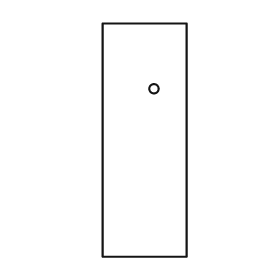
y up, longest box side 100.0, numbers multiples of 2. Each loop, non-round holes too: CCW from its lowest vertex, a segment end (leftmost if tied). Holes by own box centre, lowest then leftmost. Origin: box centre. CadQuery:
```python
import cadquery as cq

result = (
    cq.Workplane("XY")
    .moveTo(-18.0, -50.0)
    .lineTo(18.0, -50.0)
    .lineTo(18.0, 50.0)
    .lineTo(-18.0, 50.0)
    .close()
    .moveTo(4.0, 22.0)
    .circle(2.0)
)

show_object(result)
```